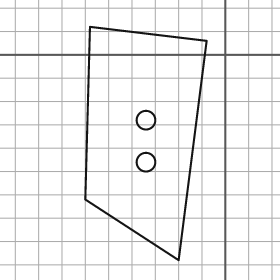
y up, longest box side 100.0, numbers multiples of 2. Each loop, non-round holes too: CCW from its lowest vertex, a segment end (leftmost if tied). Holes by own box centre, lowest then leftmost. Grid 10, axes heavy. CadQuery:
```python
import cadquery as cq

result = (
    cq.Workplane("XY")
    .moveTo(-20.0, -88.0)
    .lineTo(-8.0, 6.0)
    .lineTo(-58.0, 12.0)
    .lineTo(-60.0, -62.0)
    .close()
    .moveTo(-34.0, -46.0)
    .circle(4.0)
    .moveTo(-34.0, -28.0)
    .circle(4.0)
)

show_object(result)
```